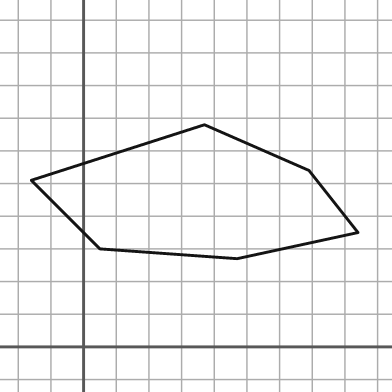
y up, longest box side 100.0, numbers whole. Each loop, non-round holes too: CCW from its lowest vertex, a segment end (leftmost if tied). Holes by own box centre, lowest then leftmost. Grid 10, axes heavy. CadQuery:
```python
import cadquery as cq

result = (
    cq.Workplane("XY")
    .moveTo(47.0, 27.0)
    .lineTo(84.0, 35.0)
    .lineTo(69.0, 54.0)
    .lineTo(37.0, 68.0)
    .lineTo(-16.0, 51.0)
    .lineTo(5.0, 30.0)
    .close()
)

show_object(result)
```